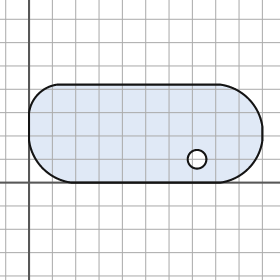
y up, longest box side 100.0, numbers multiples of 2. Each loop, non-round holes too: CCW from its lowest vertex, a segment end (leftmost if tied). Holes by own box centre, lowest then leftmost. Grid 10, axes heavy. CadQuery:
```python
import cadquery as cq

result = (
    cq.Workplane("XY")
    .moveTo(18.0, 0.0)
    .lineTo(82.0, 0.0)
    .threePointArc((94.0, 6.0), (100.0, 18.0))
    .lineTo(100.0, 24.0)
    .threePointArc((94.0, 36.0), (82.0, 42.0))
    .lineTo(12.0, 42.0)
    .threePointArc((4.0, 38.0), (0.0, 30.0))
    .lineTo(0.0, 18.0)
    .threePointArc((6.0, 6.0), (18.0, 0.0))
    .close()
    .moveTo(72.0, 10.0)
    .circle(4.0)
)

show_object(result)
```